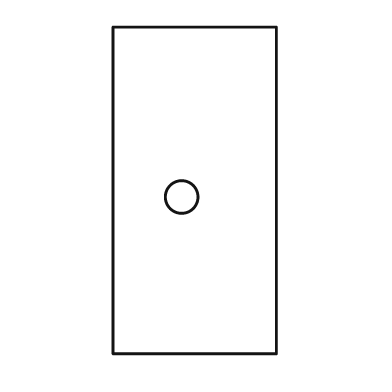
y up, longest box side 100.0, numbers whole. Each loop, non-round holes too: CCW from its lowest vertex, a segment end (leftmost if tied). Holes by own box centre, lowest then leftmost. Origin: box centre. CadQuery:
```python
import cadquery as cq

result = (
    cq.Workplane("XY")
    .moveTo(-25.0, -50.0)
    .lineTo(25.0, -50.0)
    .lineTo(25.0, 50.0)
    .lineTo(-25.0, 50.0)
    .close()
    .moveTo(-4.0, -2.0)
    .circle(5.0)
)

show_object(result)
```